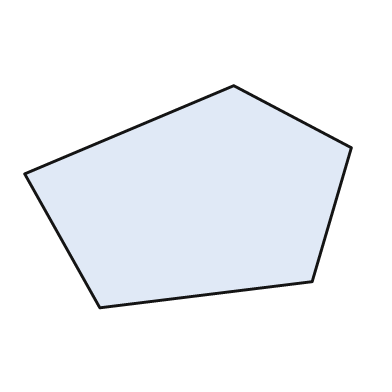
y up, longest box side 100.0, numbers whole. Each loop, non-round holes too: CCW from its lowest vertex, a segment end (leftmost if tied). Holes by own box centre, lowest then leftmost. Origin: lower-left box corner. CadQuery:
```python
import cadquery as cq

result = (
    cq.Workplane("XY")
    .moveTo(23.0, 0.0)
    .lineTo(88.0, 8.0)
    .lineTo(100.0, 49.0)
    .lineTo(64.0, 68.0)
    .lineTo(0.0, 41.0)
    .close()
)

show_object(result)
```